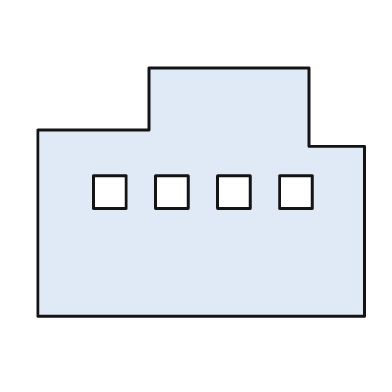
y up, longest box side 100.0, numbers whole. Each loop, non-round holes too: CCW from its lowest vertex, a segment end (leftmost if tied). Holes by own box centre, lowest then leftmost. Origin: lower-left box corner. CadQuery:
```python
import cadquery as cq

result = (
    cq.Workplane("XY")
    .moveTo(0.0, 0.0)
    .lineTo(100.0, 0.0)
    .lineTo(100.0, 52.0)
    .lineTo(83.0, 52.0)
    .lineTo(83.0, 76.0)
    .lineTo(34.0, 76.0)
    .lineTo(34.0, 57.0)
    .lineTo(0.0, 57.0)
    .close()
    .moveTo(17.0, 33.0)
    .lineTo(27.0, 33.0)
    .lineTo(27.0, 43.0)
    .lineTo(17.0, 43.0)
    .close()
    .moveTo(36.0, 33.0)
    .lineTo(46.0, 33.0)
    .lineTo(46.0, 43.0)
    .lineTo(36.0, 43.0)
    .close()
    .moveTo(55.0, 33.0)
    .lineTo(65.0, 33.0)
    .lineTo(65.0, 43.0)
    .lineTo(55.0, 43.0)
    .close()
    .moveTo(74.0, 33.0)
    .lineTo(84.0, 33.0)
    .lineTo(84.0, 43.0)
    .lineTo(74.0, 43.0)
    .close()
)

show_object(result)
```